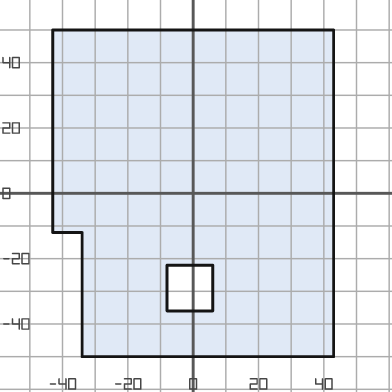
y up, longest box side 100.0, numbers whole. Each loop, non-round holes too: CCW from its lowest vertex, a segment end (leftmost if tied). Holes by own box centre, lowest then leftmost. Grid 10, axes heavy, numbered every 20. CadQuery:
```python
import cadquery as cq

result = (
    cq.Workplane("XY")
    .moveTo(-34.0, -50.0)
    .lineTo(43.0, -50.0)
    .lineTo(43.0, 50.0)
    .lineTo(-43.0, 50.0)
    .lineTo(-43.0, -12.0)
    .lineTo(-34.0, -12.0)
    .close()
    .moveTo(-8.0, -36.0)
    .lineTo(6.0, -36.0)
    .lineTo(6.0, -22.0)
    .lineTo(-8.0, -22.0)
    .close()
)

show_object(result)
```